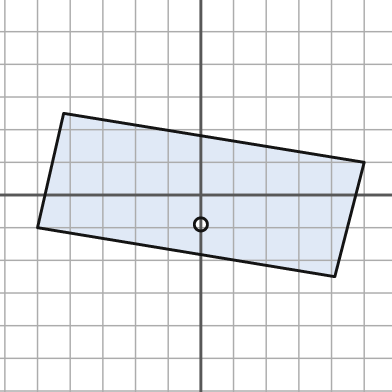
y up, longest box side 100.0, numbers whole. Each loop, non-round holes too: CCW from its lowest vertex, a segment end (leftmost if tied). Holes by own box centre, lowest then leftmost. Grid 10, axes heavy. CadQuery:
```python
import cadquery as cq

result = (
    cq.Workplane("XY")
    .moveTo(41.0, -25.0)
    .lineTo(50.0, 10.0)
    .lineTo(-42.0, 25.0)
    .lineTo(-50.0, -10.0)
    .close()
    .moveTo(0.0, -9.0)
    .circle(2.0)
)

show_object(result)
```